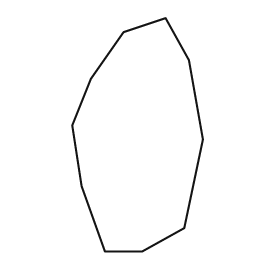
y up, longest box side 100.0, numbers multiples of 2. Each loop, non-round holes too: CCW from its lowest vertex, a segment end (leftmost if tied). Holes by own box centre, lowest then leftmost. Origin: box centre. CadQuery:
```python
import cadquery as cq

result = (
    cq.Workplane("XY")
    .moveTo(-14.0, -50.0)
    .lineTo(2.0, -50.0)
    .lineTo(20.0, -40.0)
    .lineTo(28.0, -2.0)
    .lineTo(22.0, 32.0)
    .lineTo(12.0, 50.0)
    .lineTo(-6.0, 44.0)
    .lineTo(-20.0, 24.0)
    .lineTo(-28.0, 4.0)
    .lineTo(-24.0, -22.0)
    .close()
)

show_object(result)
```